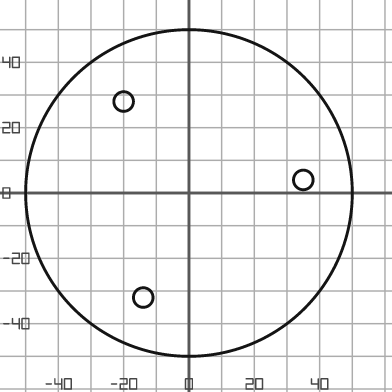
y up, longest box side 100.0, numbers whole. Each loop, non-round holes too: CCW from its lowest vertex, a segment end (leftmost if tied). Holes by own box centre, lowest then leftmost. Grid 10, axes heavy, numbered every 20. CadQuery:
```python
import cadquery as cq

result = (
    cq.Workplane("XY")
    .moveTo(0.0, 0.0)
    .circle(50.0)
    .moveTo(-14.0, -32.0)
    .circle(3.0)
    .moveTo(35.0, 4.0)
    .circle(3.0)
    .moveTo(-20.0, 28.0)
    .circle(3.0)
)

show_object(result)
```